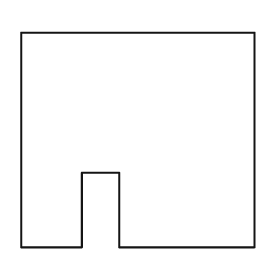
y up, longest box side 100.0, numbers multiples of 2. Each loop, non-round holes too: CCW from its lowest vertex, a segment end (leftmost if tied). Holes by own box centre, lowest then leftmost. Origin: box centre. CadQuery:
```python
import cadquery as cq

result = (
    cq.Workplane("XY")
    .moveTo(-50.0, -46.0)
    .lineTo(-24.0, -46.0)
    .lineTo(-24.0, -14.0)
    .lineTo(-8.0, -14.0)
    .lineTo(-8.0, -46.0)
    .lineTo(50.0, -46.0)
    .lineTo(50.0, 46.0)
    .lineTo(-50.0, 46.0)
    .close()
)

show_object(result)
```